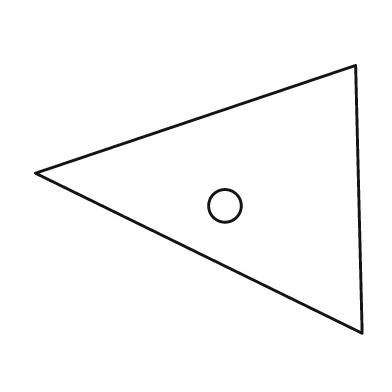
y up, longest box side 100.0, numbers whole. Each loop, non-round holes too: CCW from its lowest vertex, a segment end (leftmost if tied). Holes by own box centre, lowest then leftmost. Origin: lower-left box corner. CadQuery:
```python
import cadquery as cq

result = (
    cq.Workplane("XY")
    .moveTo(100.0, 0.0)
    .lineTo(98.0, 82.0)
    .lineTo(0.0, 49.0)
    .close()
    .moveTo(58.0, 39.0)
    .circle(5.0)
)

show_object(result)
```